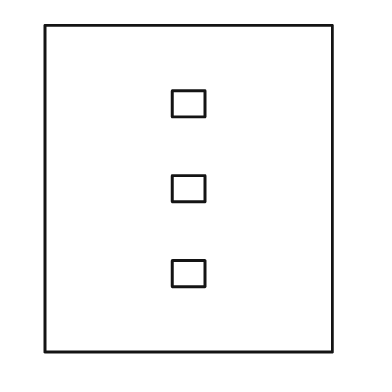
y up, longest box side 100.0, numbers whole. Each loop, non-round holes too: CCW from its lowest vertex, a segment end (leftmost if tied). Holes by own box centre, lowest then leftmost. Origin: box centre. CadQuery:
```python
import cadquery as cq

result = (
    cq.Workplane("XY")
    .moveTo(-44.0, -50.0)
    .lineTo(44.0, -50.0)
    .lineTo(44.0, 50.0)
    .lineTo(-44.0, 50.0)
    .close()
    .moveTo(-5.0, -30.0)
    .lineTo(5.0, -30.0)
    .lineTo(5.0, -22.0)
    .lineTo(-5.0, -22.0)
    .close()
    .moveTo(-5.0, -4.0)
    .lineTo(5.0, -4.0)
    .lineTo(5.0, 4.0)
    .lineTo(-5.0, 4.0)
    .close()
    .moveTo(-5.0, 22.0)
    .lineTo(5.0, 22.0)
    .lineTo(5.0, 30.0)
    .lineTo(-5.0, 30.0)
    .close()
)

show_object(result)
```